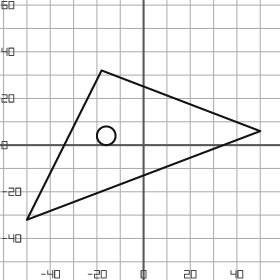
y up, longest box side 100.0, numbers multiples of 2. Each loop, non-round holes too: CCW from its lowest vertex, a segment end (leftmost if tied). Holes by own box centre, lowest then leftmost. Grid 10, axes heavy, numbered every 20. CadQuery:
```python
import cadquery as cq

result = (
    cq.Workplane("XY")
    .moveTo(-50.0, -32.0)
    .lineTo(50.0, 6.0)
    .lineTo(-18.0, 32.0)
    .close()
    .moveTo(-16.0, 4.0)
    .circle(4.0)
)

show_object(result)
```